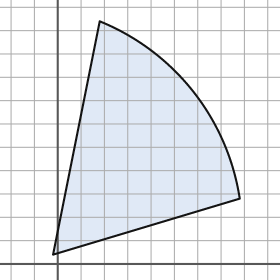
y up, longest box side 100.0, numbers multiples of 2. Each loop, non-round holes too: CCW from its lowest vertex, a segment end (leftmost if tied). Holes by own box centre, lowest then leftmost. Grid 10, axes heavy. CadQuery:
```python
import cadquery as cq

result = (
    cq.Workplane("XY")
    .moveTo(-2.0, 4.0)
    .lineTo(78.0, 28.0)
    .threePointArc((58.0, 74.0), (18.0, 104.0))
    .close()
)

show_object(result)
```